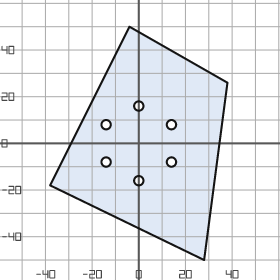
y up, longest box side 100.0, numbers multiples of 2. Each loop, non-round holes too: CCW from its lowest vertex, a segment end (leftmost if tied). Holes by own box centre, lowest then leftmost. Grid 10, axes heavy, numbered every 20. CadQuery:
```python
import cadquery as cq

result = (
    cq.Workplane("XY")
    .moveTo(28.0, -50.0)
    .lineTo(38.0, 26.0)
    .lineTo(-4.0, 50.0)
    .lineTo(-38.0, -18.0)
    .close()
    .moveTo(0.0, -16.0)
    .circle(2.0)
    .moveTo(-14.0, -8.0)
    .circle(2.0)
    .moveTo(14.0, -8.0)
    .circle(2.0)
    .moveTo(-14.0, 8.0)
    .circle(2.0)
    .moveTo(14.0, 8.0)
    .circle(2.0)
    .moveTo(0.0, 16.0)
    .circle(2.0)
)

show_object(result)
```